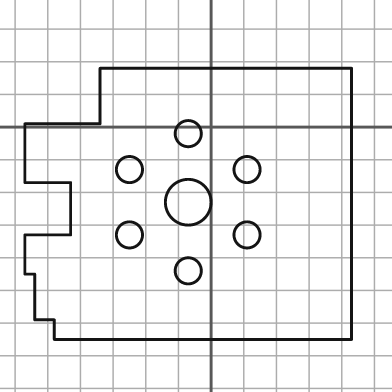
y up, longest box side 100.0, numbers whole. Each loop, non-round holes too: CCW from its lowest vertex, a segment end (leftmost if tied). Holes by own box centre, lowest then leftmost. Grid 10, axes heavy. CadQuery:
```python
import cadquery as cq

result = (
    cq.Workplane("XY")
    .moveTo(-48.0, -65.0)
    .lineTo(43.0, -65.0)
    .lineTo(43.0, 18.0)
    .lineTo(-34.0, 18.0)
    .lineTo(-34.0, 1.0)
    .lineTo(-57.0, 1.0)
    .lineTo(-57.0, -17.0)
    .lineTo(-43.0, -17.0)
    .lineTo(-43.0, -33.0)
    .lineTo(-57.0, -33.0)
    .lineTo(-57.0, -45.0)
    .lineTo(-54.0, -45.0)
    .lineTo(-54.0, -59.0)
    .lineTo(-48.0, -59.0)
    .close()
    .moveTo(-7.0, -44.0)
    .circle(4.0)
    .moveTo(-25.0, -33.0)
    .circle(4.0)
    .moveTo(11.0, -33.0)
    .circle(4.0)
    .moveTo(-7.0, -23.0)
    .circle(7.0)
    .moveTo(-25.0, -13.0)
    .circle(4.0)
    .moveTo(11.0, -13.0)
    .circle(4.0)
    .moveTo(-7.0, -2.0)
    .circle(4.0)
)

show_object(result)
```